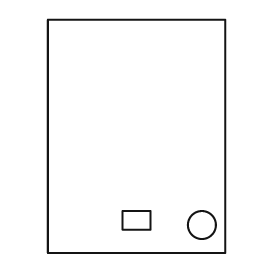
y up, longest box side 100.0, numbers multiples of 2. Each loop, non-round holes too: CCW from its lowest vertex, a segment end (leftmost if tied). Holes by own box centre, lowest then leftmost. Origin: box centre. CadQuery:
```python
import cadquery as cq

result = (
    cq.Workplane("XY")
    .moveTo(-38.0, -50.0)
    .lineTo(38.0, -50.0)
    .lineTo(38.0, 50.0)
    .lineTo(-38.0, 50.0)
    .close()
    .moveTo(28.0, -38.0)
    .circle(6.0)
    .moveTo(-6.0, -40.0)
    .lineTo(6.0, -40.0)
    .lineTo(6.0, -32.0)
    .lineTo(-6.0, -32.0)
    .close()
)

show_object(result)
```